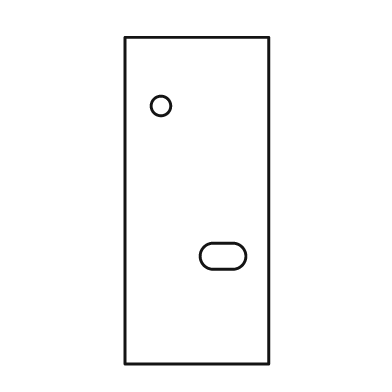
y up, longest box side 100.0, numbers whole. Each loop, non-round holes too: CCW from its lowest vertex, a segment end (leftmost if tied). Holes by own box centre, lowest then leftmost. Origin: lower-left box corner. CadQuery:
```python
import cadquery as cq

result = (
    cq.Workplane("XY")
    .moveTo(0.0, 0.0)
    .lineTo(44.0, 0.0)
    .lineTo(44.0, 100.0)
    .lineTo(0.0, 100.0)
    .close()
    .moveTo(27.0, 29.0)
    .lineTo(33.0, 29.0)
    .threePointArc((37.0, 33.0), (33.0, 37.0))
    .lineTo(27.0, 37.0)
    .threePointArc((23.0, 33.0), (27.0, 29.0))
    .close()
    .moveTo(11.0, 79.0)
    .circle(3.0)
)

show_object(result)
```